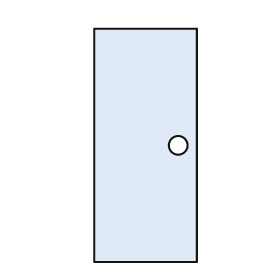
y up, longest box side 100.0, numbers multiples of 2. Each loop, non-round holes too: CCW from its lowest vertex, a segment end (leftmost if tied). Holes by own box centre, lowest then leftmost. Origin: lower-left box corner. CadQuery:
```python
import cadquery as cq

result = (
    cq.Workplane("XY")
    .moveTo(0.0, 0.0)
    .lineTo(44.0, 0.0)
    .lineTo(44.0, 100.0)
    .lineTo(0.0, 100.0)
    .close()
    .moveTo(36.0, 50.0)
    .circle(4.0)
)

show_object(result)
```